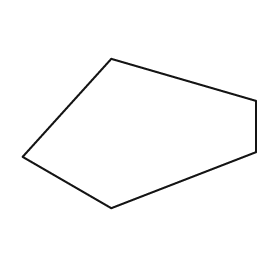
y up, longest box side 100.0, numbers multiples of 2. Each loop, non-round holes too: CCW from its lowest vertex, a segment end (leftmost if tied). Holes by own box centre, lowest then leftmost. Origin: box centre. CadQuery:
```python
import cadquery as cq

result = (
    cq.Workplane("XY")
    .moveTo(-12.0, -32.0)
    .lineTo(50.0, -8.0)
    .lineTo(50.0, 14.0)
    .lineTo(-12.0, 32.0)
    .lineTo(-50.0, -10.0)
    .close()
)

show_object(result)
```